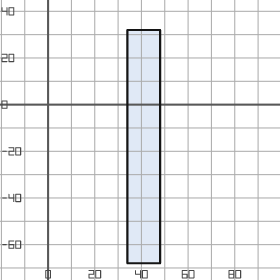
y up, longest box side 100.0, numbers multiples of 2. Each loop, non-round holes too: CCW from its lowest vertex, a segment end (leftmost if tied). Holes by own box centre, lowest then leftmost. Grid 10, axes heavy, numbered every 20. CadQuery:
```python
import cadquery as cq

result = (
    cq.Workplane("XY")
    .moveTo(34.0, -68.0)
    .lineTo(48.0, -68.0)
    .lineTo(48.0, 32.0)
    .lineTo(34.0, 32.0)
    .close()
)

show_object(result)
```